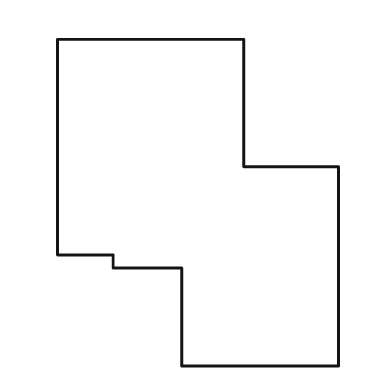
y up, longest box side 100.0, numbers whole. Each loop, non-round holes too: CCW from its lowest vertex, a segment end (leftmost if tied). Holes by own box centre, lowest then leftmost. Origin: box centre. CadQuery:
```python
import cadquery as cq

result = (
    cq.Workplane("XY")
    .moveTo(-5.0, -50.0)
    .lineTo(43.0, -50.0)
    .lineTo(43.0, 11.0)
    .lineTo(14.0, 11.0)
    .lineTo(14.0, 50.0)
    .lineTo(-43.0, 50.0)
    .lineTo(-43.0, -16.0)
    .lineTo(-26.0, -16.0)
    .lineTo(-26.0, -20.0)
    .lineTo(-5.0, -20.0)
    .close()
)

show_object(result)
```